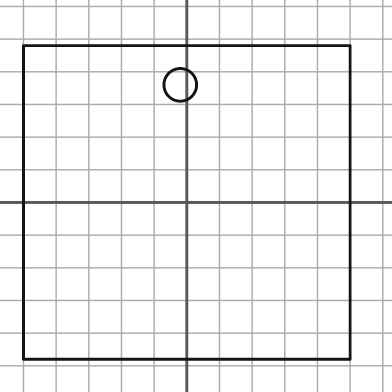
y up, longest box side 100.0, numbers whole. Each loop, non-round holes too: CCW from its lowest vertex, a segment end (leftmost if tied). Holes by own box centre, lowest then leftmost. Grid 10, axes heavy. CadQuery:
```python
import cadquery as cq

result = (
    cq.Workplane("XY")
    .moveTo(-50.0, -48.0)
    .lineTo(50.0, -48.0)
    .lineTo(50.0, 48.0)
    .lineTo(-50.0, 48.0)
    .close()
    .moveTo(-2.0, 36.0)
    .circle(5.0)
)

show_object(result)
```